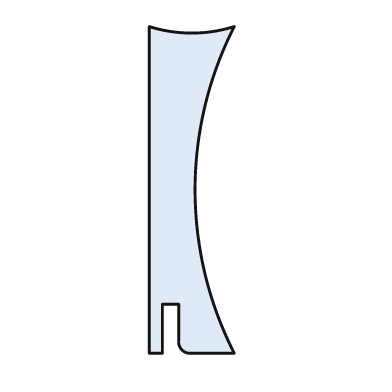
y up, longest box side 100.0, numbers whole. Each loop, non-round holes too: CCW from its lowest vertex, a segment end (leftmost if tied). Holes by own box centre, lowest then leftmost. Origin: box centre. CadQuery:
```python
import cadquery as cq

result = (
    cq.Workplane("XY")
    .moveTo(-13.0, -50.0)
    .lineTo(-9.0, -50.0)
    .lineTo(-9.0, -35.0)
    .lineTo(-4.0, -35.0)
    .lineTo(-4.0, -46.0)
    .threePointArc((-3.0, -49.0), (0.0, -50.0))
    .lineTo(13.0, -50.0)
    .threePointArc((1.0, 0.0), (13.0, 50.0))
    .threePointArc((0.0, 48.0), (-13.0, 50.0))
    .close()
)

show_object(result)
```